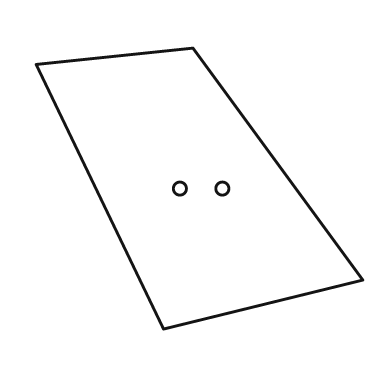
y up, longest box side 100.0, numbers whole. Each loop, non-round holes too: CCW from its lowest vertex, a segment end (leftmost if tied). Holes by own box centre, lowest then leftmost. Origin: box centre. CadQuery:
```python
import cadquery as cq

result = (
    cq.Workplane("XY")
    .moveTo(-11.0, -43.0)
    .lineTo(50.0, -28.0)
    .lineTo(-2.0, 43.0)
    .lineTo(-50.0, 38.0)
    .close()
    .moveTo(-6.0, 0.0)
    .circle(2.0)
    .moveTo(7.0, 0.0)
    .circle(2.0)
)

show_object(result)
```